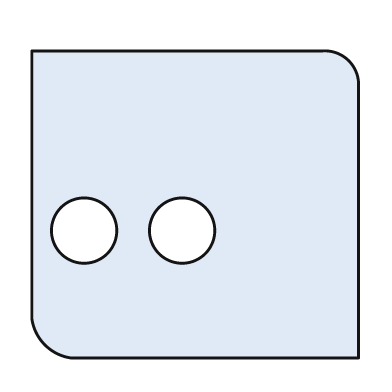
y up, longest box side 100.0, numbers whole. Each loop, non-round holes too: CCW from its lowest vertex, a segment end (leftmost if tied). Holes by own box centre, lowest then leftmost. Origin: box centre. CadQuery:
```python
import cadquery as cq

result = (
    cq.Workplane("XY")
    .moveTo(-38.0, -47.0)
    .lineTo(50.0, -47.0)
    .lineTo(50.0, 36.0)
    .threePointArc((47.0, 44.0), (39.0, 47.0))
    .lineTo(-50.0, 47.0)
    .lineTo(-50.0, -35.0)
    .threePointArc((-46.0, -43.0), (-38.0, -47.0))
    .close()
    .moveTo(-34.0, -8.0)
    .circle(10.0)
    .moveTo(-4.0, -8.0)
    .circle(10.0)
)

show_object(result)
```